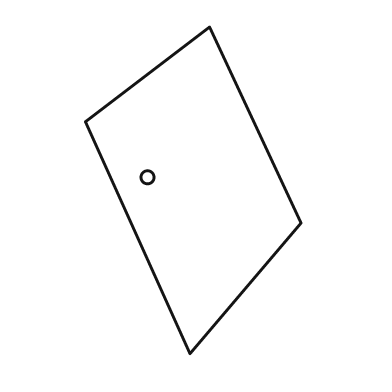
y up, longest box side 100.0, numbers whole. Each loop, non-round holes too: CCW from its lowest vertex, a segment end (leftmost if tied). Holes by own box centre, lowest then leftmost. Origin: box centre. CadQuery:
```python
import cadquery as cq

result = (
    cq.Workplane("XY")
    .moveTo(-1.0, -50.0)
    .lineTo(33.0, -10.0)
    .lineTo(5.0, 50.0)
    .lineTo(-33.0, 21.0)
    .close()
    .moveTo(-14.0, 4.0)
    .circle(2.0)
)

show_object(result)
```